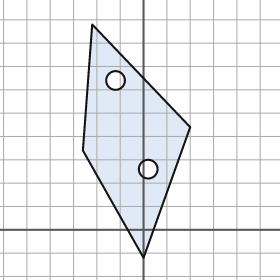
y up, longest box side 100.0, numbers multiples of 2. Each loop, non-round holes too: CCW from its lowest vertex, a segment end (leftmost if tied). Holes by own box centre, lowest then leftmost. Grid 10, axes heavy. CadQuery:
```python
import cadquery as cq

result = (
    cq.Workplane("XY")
    .moveTo(0.0, -12.0)
    .lineTo(20.0, 44.0)
    .lineTo(-22.0, 88.0)
    .lineTo(-26.0, 34.0)
    .close()
    .moveTo(2.0, 26.0)
    .circle(4.0)
    .moveTo(-12.0, 64.0)
    .circle(4.0)
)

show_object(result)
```